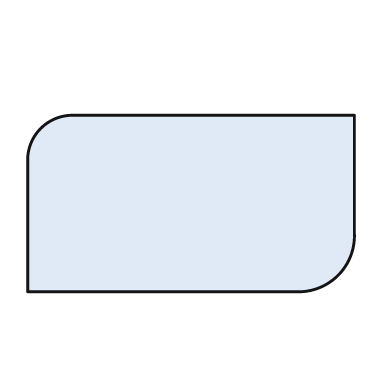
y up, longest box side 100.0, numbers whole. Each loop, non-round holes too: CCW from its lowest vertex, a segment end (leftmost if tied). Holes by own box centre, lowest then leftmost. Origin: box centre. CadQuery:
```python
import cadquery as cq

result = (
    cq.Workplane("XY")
    .moveTo(-50.0, -27.0)
    .lineTo(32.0, -27.0)
    .threePointArc((45.0, -22.0), (50.0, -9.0))
    .lineTo(50.0, 27.0)
    .lineTo(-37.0, 27.0)
    .threePointArc((-46.0, 23.0), (-50.0, 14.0))
    .close()
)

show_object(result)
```